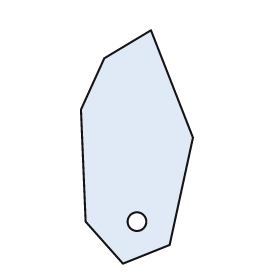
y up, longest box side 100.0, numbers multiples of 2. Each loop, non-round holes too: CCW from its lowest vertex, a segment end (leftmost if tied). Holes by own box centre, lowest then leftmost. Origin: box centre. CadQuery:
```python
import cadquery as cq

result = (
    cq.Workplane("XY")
    .moveTo(-6.0, -50.0)
    .lineTo(14.0, -42.0)
    .lineTo(24.0, 4.0)
    .lineTo(6.0, 50.0)
    .lineTo(-14.0, 38.0)
    .lineTo(-24.0, 16.0)
    .lineTo(-22.0, -32.0)
    .close()
    .moveTo(0.0, -32.0)
    .circle(4.0)
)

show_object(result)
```